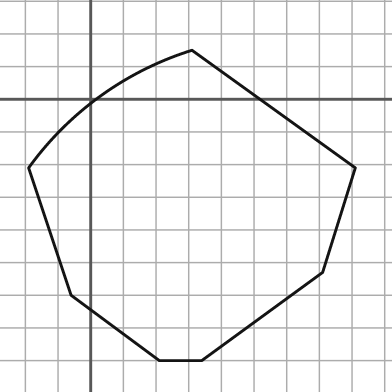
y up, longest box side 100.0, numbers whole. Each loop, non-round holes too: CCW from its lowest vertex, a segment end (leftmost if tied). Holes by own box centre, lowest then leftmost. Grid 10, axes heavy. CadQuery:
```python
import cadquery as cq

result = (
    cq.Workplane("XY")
    .moveTo(21.0, -80.0)
    .lineTo(34.0, -80.0)
    .lineTo(71.0, -53.0)
    .lineTo(81.0, -21.0)
    .lineTo(31.0, 15.0)
    .threePointArc((3.0, 1.0), (-19.0, -21.0))
    .lineTo(-6.0, -60.0)
    .close()
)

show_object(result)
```